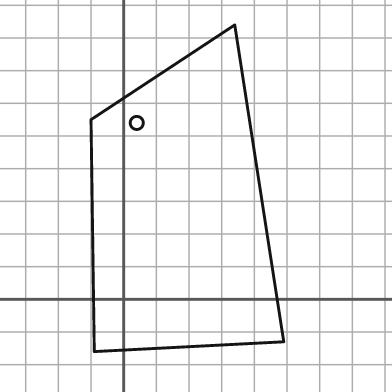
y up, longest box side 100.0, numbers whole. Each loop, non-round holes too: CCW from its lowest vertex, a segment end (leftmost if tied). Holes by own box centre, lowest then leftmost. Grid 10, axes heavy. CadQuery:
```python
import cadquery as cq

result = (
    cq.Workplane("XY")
    .moveTo(-9.0, -16.0)
    .lineTo(49.0, -13.0)
    .lineTo(34.0, 84.0)
    .lineTo(-10.0, 55.0)
    .close()
    .moveTo(4.0, 54.0)
    .circle(2.0)
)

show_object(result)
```